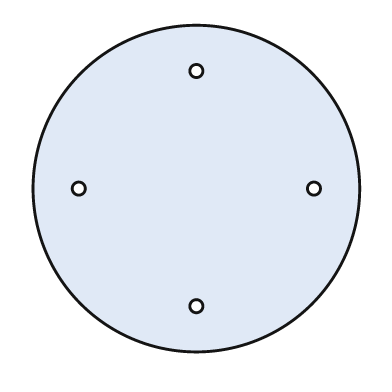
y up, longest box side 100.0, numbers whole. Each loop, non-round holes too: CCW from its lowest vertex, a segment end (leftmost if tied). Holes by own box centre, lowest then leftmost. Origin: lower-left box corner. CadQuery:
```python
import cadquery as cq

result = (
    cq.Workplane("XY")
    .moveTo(50.0, 50.0)
    .circle(50.0)
    .moveTo(50.0, 14.0)
    .circle(2.0)
    .moveTo(14.0, 50.0)
    .circle(2.0)
    .moveTo(86.0, 50.0)
    .circle(2.0)
    .moveTo(50.0, 86.0)
    .circle(2.0)
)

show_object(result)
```